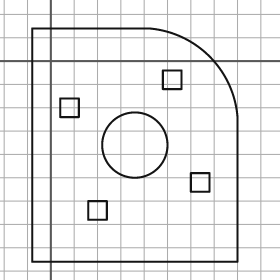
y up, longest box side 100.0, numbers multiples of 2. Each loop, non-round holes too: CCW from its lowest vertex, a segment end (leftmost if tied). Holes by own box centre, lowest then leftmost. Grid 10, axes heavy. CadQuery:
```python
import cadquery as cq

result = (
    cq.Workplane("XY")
    .moveTo(-8.0, -86.0)
    .lineTo(80.0, -86.0)
    .lineTo(80.0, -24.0)
    .threePointArc((68.0, 2.0), (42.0, 14.0))
    .lineTo(-8.0, 14.0)
    .close()
    .moveTo(16.0, -68.0)
    .lineTo(24.0, -68.0)
    .lineTo(24.0, -60.0)
    .lineTo(16.0, -60.0)
    .close()
    .moveTo(60.0, -56.0)
    .lineTo(68.0, -56.0)
    .lineTo(68.0, -48.0)
    .lineTo(60.0, -48.0)
    .close()
    .moveTo(36.0, -36.0)
    .circle(14.0)
    .moveTo(4.0, -24.0)
    .lineTo(12.0, -24.0)
    .lineTo(12.0, -16.0)
    .lineTo(4.0, -16.0)
    .close()
    .moveTo(48.0, -12.0)
    .lineTo(56.0, -12.0)
    .lineTo(56.0, -4.0)
    .lineTo(48.0, -4.0)
    .close()
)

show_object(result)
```